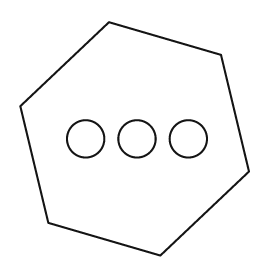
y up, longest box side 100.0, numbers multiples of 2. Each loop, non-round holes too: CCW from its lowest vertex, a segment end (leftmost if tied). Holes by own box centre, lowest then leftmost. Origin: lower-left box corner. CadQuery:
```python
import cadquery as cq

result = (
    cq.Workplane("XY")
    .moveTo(60.0, 0.0)
    .lineTo(98.0, 36.0)
    .lineTo(86.0, 86.0)
    .lineTo(38.0, 100.0)
    .lineTo(0.0, 64.0)
    .lineTo(12.0, 14.0)
    .close()
    .moveTo(28.0, 50.0)
    .circle(8.0)
    .moveTo(50.0, 50.0)
    .circle(8.0)
    .moveTo(72.0, 50.0)
    .circle(8.0)
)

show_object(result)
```